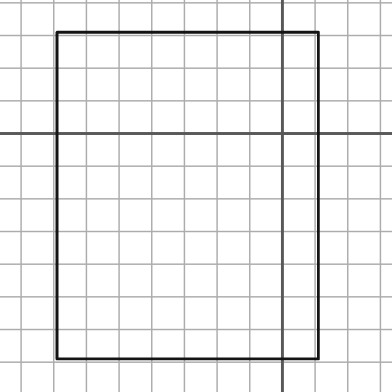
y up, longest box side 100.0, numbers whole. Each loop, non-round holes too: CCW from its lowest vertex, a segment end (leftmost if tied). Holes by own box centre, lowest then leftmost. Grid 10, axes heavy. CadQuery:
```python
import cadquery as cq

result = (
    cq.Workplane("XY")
    .moveTo(-69.0, -69.0)
    .lineTo(11.0, -69.0)
    .lineTo(11.0, 31.0)
    .lineTo(-69.0, 31.0)
    .close()
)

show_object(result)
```